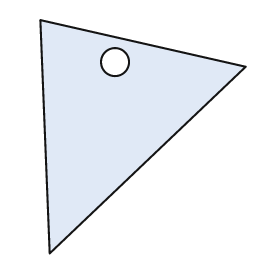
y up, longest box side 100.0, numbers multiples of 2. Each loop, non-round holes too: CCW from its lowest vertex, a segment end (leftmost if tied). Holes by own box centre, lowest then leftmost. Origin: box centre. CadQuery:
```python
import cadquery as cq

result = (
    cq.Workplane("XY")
    .moveTo(-40.0, -50.0)
    .lineTo(44.0, 30.0)
    .lineTo(-44.0, 50.0)
    .close()
    .moveTo(-12.0, 32.0)
    .circle(6.0)
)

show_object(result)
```